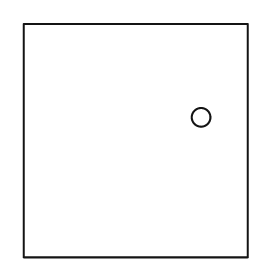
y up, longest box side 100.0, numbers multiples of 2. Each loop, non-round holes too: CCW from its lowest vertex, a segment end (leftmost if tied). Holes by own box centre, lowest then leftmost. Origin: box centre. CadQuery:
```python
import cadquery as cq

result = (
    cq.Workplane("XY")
    .moveTo(-48.0, -50.0)
    .lineTo(48.0, -50.0)
    .lineTo(48.0, 50.0)
    .lineTo(-48.0, 50.0)
    .close()
    .moveTo(28.0, 10.0)
    .circle(4.0)
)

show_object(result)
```